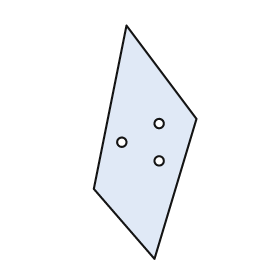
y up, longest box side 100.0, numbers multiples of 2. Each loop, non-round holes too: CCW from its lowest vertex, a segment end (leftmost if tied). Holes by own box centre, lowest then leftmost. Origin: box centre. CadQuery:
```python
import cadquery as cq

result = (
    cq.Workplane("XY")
    .moveTo(4.0, -50.0)
    .lineTo(22.0, 10.0)
    .lineTo(-8.0, 50.0)
    .lineTo(-22.0, -20.0)
    .close()
    .moveTo(6.0, -8.0)
    .circle(2.0)
    .moveTo(-10.0, 0.0)
    .circle(2.0)
    .moveTo(6.0, 8.0)
    .circle(2.0)
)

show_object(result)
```